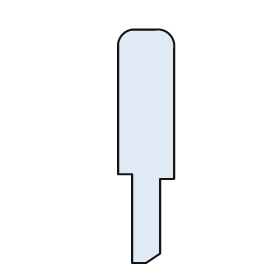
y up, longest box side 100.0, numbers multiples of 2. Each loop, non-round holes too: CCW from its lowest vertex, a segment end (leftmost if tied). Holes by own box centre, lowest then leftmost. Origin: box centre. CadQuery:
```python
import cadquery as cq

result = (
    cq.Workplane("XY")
    .moveTo(-6.0, -50.0)
    .lineTo(0.0, -50.0)
    .lineTo(6.0, -46.0)
    .lineTo(6.0, -14.0)
    .lineTo(12.0, -14.0)
    .lineTo(12.0, 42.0)
    .threePointArc((10.0, 48.0), (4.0, 50.0))
    .lineTo(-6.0, 50.0)
    .threePointArc((-10.0, 48.0), (-12.0, 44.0))
    .lineTo(-12.0, -12.0)
    .lineTo(-6.0, -12.0)
    .close()
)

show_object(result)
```